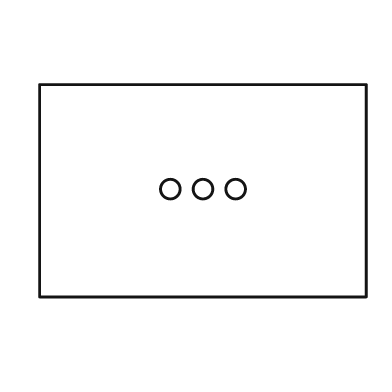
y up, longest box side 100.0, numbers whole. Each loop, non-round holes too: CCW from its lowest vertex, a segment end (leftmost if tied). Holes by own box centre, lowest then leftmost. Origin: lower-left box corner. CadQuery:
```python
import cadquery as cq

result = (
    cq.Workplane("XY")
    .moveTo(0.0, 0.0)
    .lineTo(100.0, 0.0)
    .lineTo(100.0, 65.0)
    .lineTo(0.0, 65.0)
    .close()
    .moveTo(40.0, 33.0)
    .circle(3.0)
    .moveTo(50.0, 33.0)
    .circle(3.0)
    .moveTo(60.0, 33.0)
    .circle(3.0)
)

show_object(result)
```